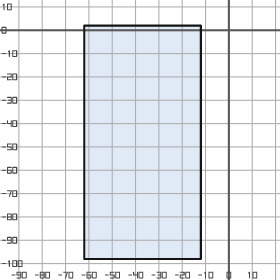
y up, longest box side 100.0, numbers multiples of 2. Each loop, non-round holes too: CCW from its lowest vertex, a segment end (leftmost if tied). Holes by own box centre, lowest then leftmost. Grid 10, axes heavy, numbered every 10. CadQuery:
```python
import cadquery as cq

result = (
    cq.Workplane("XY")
    .moveTo(-62.0, -98.0)
    .lineTo(-12.0, -98.0)
    .lineTo(-12.0, 2.0)
    .lineTo(-62.0, 2.0)
    .close()
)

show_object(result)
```